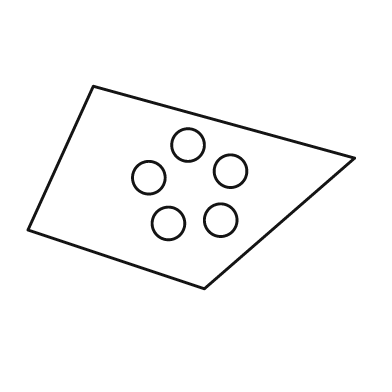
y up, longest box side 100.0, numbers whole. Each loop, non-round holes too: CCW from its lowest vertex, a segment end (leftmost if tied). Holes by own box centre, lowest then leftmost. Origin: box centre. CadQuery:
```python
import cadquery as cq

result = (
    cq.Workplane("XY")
    .moveTo(4.0, -31.0)
    .lineTo(50.0, 9.0)
    .lineTo(-30.0, 31.0)
    .lineTo(-50.0, -13.0)
    .close()
    .moveTo(-7.0, -11.0)
    .circle(5.0)
    .moveTo(9.0, -10.0)
    .circle(5.0)
    .moveTo(-13.0, 3.0)
    .circle(5.0)
    .moveTo(12.0, 5.0)
    .circle(5.0)
    .moveTo(-1.0, 13.0)
    .circle(5.0)
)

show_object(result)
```